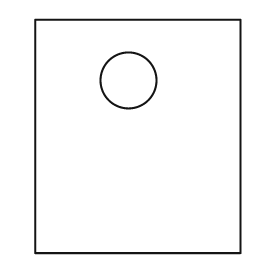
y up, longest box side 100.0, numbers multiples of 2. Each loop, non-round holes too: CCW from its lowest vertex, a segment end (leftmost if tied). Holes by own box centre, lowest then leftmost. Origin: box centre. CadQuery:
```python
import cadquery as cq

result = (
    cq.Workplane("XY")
    .moveTo(-44.0, -50.0)
    .lineTo(44.0, -50.0)
    .lineTo(44.0, 50.0)
    .lineTo(-44.0, 50.0)
    .close()
    .moveTo(-4.0, 24.0)
    .circle(12.0)
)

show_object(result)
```